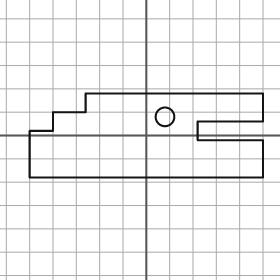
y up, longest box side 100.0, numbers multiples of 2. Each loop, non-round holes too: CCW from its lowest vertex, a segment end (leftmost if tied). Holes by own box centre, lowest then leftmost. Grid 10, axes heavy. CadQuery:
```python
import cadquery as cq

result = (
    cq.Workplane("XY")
    .moveTo(-50.0, -18.0)
    .lineTo(50.0, -18.0)
    .lineTo(50.0, -2.0)
    .lineTo(22.0, -2.0)
    .lineTo(22.0, 6.0)
    .lineTo(50.0, 6.0)
    .lineTo(50.0, 18.0)
    .lineTo(-26.0, 18.0)
    .lineTo(-26.0, 10.0)
    .lineTo(-40.0, 10.0)
    .lineTo(-40.0, 2.0)
    .lineTo(-50.0, 2.0)
    .close()
    .moveTo(8.0, 8.0)
    .circle(4.0)
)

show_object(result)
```